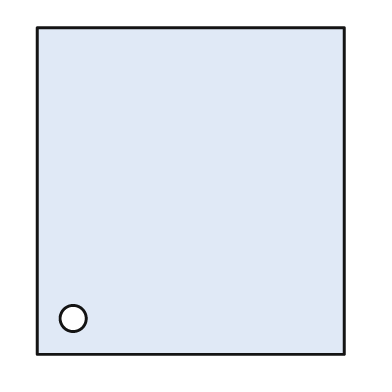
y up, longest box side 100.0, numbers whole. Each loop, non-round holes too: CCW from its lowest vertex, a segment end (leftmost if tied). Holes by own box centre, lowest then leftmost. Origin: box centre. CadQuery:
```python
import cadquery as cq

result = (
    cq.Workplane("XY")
    .moveTo(-47.0, -50.0)
    .lineTo(47.0, -50.0)
    .lineTo(47.0, 50.0)
    .lineTo(-47.0, 50.0)
    .close()
    .moveTo(-36.0, -39.0)
    .circle(4.0)
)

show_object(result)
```